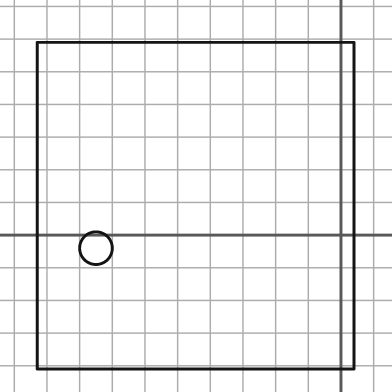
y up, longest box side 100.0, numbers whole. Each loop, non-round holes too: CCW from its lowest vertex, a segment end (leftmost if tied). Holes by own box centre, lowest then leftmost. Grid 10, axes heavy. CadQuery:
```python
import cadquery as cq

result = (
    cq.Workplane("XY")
    .moveTo(-93.0, -41.0)
    .lineTo(4.0, -41.0)
    .lineTo(4.0, 59.0)
    .lineTo(-93.0, 59.0)
    .close()
    .moveTo(-75.0, -4.0)
    .circle(5.0)
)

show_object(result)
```